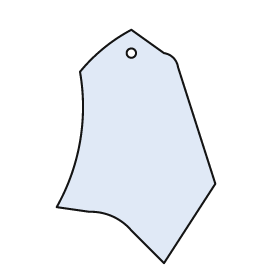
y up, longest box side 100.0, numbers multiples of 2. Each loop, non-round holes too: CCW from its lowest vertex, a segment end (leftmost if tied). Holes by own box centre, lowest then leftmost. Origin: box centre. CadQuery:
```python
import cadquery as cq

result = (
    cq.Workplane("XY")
    .moveTo(12.0, -50.0)
    .lineTo(34.0, -16.0)
    .lineTo(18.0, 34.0)
    .threePointArc((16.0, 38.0), (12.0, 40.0))
    .lineTo(-2.0, 50.0)
    .threePointArc((-14.0, 42.0), (-24.0, 32.0))
    .threePointArc((-24.0, 2.0), (-34.0, -26.0))
    .lineTo(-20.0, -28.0)
    .threePointArc((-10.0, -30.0), (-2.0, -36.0))
    .close()
    .moveTo(-2.0, 40.0)
    .circle(2.0)
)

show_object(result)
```